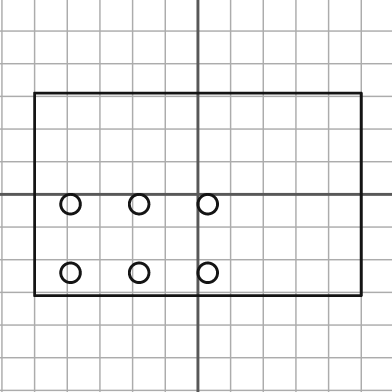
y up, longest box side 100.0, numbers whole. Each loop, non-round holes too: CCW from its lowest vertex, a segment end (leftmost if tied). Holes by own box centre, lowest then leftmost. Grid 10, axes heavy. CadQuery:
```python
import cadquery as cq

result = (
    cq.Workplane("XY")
    .moveTo(-50.0, -31.0)
    .lineTo(50.0, -31.0)
    .lineTo(50.0, 31.0)
    .lineTo(-50.0, 31.0)
    .close()
    .moveTo(-39.0, -24.0)
    .circle(3.0)
    .moveTo(-18.0, -24.0)
    .circle(3.0)
    .moveTo(3.0, -24.0)
    .circle(3.0)
    .moveTo(-39.0, -3.0)
    .circle(3.0)
    .moveTo(-18.0, -3.0)
    .circle(3.0)
    .moveTo(3.0, -3.0)
    .circle(3.0)
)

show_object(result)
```